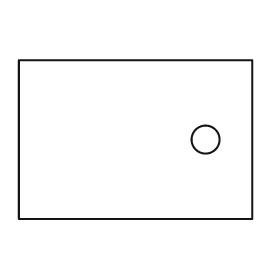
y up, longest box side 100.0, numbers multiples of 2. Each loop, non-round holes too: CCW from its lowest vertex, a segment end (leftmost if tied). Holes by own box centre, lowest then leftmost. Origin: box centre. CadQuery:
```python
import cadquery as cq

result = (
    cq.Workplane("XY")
    .moveTo(-50.0, -34.0)
    .lineTo(50.0, -34.0)
    .lineTo(50.0, 34.0)
    .lineTo(-50.0, 34.0)
    .close()
    .moveTo(30.0, 0.0)
    .circle(6.0)
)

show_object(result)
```